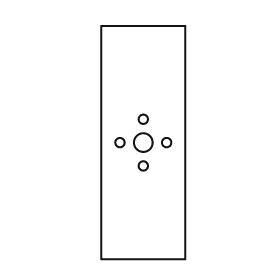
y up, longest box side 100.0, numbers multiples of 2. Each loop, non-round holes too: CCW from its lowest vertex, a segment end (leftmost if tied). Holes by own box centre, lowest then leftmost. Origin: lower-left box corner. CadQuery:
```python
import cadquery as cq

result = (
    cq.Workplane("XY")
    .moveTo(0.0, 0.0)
    .lineTo(36.0, 0.0)
    .lineTo(36.0, 100.0)
    .lineTo(0.0, 100.0)
    .close()
    .moveTo(18.0, 40.0)
    .circle(2.0)
    .moveTo(8.0, 50.0)
    .circle(2.0)
    .moveTo(18.0, 50.0)
    .circle(4.0)
    .moveTo(28.0, 50.0)
    .circle(2.0)
    .moveTo(18.0, 60.0)
    .circle(2.0)
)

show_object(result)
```